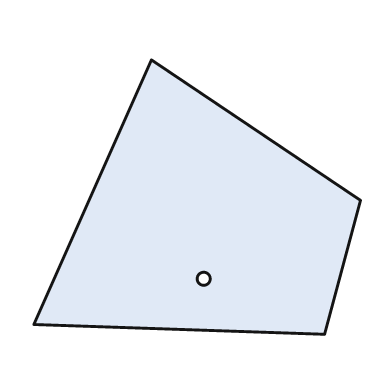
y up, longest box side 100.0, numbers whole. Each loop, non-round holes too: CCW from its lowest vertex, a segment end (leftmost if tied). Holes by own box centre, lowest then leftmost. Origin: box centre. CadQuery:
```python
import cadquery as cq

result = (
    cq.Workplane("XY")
    .moveTo(39.0, -42.0)
    .lineTo(50.0, -1.0)
    .lineTo(-14.0, 42.0)
    .lineTo(-50.0, -39.0)
    .close()
    .moveTo(2.0, -25.0)
    .circle(2.0)
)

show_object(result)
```